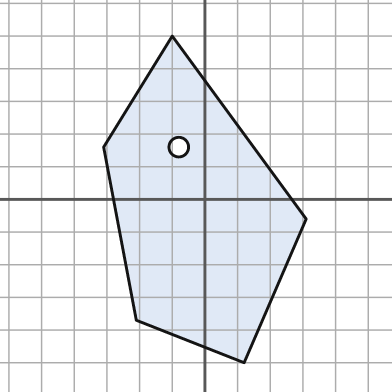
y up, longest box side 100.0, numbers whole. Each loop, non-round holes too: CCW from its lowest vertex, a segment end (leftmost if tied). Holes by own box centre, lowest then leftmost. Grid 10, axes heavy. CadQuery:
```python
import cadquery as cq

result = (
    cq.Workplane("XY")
    .moveTo(12.0, -50.0)
    .lineTo(31.0, -6.0)
    .lineTo(-10.0, 50.0)
    .lineTo(-31.0, 16.0)
    .lineTo(-21.0, -37.0)
    .close()
    .moveTo(-8.0, 16.0)
    .circle(3.0)
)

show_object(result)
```